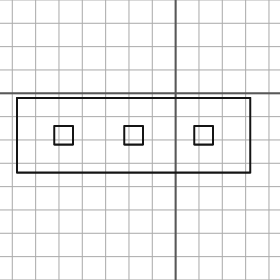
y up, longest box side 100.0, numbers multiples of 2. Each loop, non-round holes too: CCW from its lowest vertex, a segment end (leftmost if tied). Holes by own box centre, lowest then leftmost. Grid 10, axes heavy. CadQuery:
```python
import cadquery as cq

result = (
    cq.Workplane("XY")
    .moveTo(-68.0, -34.0)
    .lineTo(32.0, -34.0)
    .lineTo(32.0, -2.0)
    .lineTo(-68.0, -2.0)
    .close()
    .moveTo(-52.0, -22.0)
    .lineTo(-44.0, -22.0)
    .lineTo(-44.0, -14.0)
    .lineTo(-52.0, -14.0)
    .close()
    .moveTo(-22.0, -22.0)
    .lineTo(-14.0, -22.0)
    .lineTo(-14.0, -14.0)
    .lineTo(-22.0, -14.0)
    .close()
    .moveTo(8.0, -22.0)
    .lineTo(16.0, -22.0)
    .lineTo(16.0, -14.0)
    .lineTo(8.0, -14.0)
    .close()
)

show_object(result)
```